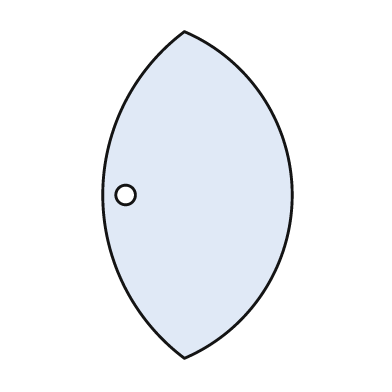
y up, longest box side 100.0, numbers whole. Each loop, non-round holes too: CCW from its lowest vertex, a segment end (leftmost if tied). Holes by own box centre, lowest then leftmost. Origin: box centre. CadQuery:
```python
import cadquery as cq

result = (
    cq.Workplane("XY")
    .moveTo(-4.0, -50.0)
    .threePointArc((29.0, 0.0), (-4.0, 50.0))
    .threePointArc((-29.0, 0.0), (-4.0, -50.0))
    .close()
    .moveTo(-22.0, 0.0)
    .circle(3.0)
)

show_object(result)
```